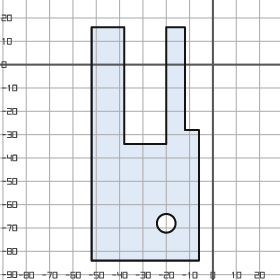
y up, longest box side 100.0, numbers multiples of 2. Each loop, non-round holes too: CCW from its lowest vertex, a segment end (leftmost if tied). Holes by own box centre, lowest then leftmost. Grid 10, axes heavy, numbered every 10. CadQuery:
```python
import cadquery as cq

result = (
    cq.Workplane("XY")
    .moveTo(-52.0, -84.0)
    .lineTo(-6.0, -84.0)
    .lineTo(-6.0, -28.0)
    .lineTo(-12.0, -28.0)
    .lineTo(-12.0, 16.0)
    .lineTo(-20.0, 16.0)
    .lineTo(-20.0, -34.0)
    .lineTo(-38.0, -34.0)
    .lineTo(-38.0, 16.0)
    .lineTo(-52.0, 16.0)
    .close()
    .moveTo(-20.0, -68.0)
    .circle(4.0)
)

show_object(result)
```